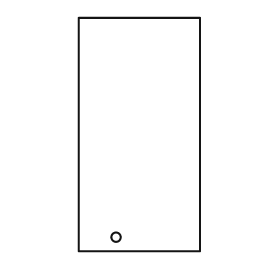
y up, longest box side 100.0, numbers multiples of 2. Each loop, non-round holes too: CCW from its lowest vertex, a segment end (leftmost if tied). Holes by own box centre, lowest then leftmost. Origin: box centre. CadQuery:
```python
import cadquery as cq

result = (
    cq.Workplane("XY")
    .moveTo(-26.0, -50.0)
    .lineTo(26.0, -50.0)
    .lineTo(26.0, 50.0)
    .lineTo(-26.0, 50.0)
    .close()
    .moveTo(-10.0, -44.0)
    .circle(2.0)
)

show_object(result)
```